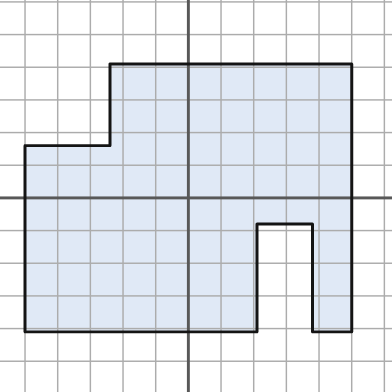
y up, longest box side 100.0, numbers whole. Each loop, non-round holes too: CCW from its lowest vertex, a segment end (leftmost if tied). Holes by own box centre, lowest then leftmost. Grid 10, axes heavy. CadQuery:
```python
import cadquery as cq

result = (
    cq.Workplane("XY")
    .moveTo(-50.0, -41.0)
    .lineTo(21.0, -41.0)
    .lineTo(21.0, -8.0)
    .lineTo(38.0, -8.0)
    .lineTo(38.0, -41.0)
    .lineTo(50.0, -41.0)
    .lineTo(50.0, 41.0)
    .lineTo(-24.0, 41.0)
    .lineTo(-24.0, 16.0)
    .lineTo(-50.0, 16.0)
    .close()
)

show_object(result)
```